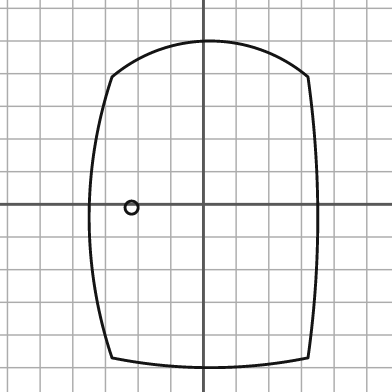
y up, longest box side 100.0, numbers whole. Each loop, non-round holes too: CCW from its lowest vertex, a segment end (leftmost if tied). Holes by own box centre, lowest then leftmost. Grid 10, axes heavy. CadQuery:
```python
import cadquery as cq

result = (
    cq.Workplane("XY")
    .moveTo(-28.0, -47.0)
    .threePointArc((2.0, -50.0), (32.0, -47.0))
    .threePointArc((35.0, -4.0), (32.0, 39.0))
    .threePointArc((2.0, 50.0), (-28.0, 39.0))
    .threePointArc((-35.0, -4.0), (-28.0, -47.0))
    .close()
    .moveTo(-22.0, -1.0)
    .circle(2.0)
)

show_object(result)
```